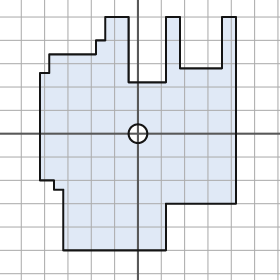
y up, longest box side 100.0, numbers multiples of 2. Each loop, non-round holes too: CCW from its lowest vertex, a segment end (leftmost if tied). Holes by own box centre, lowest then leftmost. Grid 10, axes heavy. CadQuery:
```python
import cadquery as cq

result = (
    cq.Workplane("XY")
    .moveTo(-32.0, -50.0)
    .lineTo(12.0, -50.0)
    .lineTo(12.0, -30.0)
    .lineTo(42.0, -30.0)
    .lineTo(42.0, 50.0)
    .lineTo(36.0, 50.0)
    .lineTo(36.0, 28.0)
    .lineTo(18.0, 28.0)
    .lineTo(18.0, 50.0)
    .lineTo(12.0, 50.0)
    .lineTo(12.0, 22.0)
    .lineTo(-4.0, 22.0)
    .lineTo(-4.0, 50.0)
    .lineTo(-14.0, 50.0)
    .lineTo(-14.0, 40.0)
    .lineTo(-18.0, 40.0)
    .lineTo(-18.0, 34.0)
    .lineTo(-38.0, 34.0)
    .lineTo(-38.0, 26.0)
    .lineTo(-42.0, 26.0)
    .lineTo(-42.0, -20.0)
    .lineTo(-36.0, -20.0)
    .lineTo(-36.0, -24.0)
    .lineTo(-32.0, -24.0)
    .close()
    .moveTo(0.0, 0.0)
    .circle(4.0)
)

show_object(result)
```